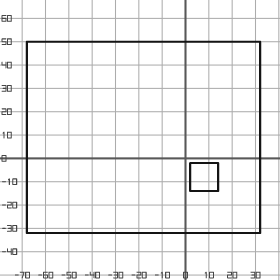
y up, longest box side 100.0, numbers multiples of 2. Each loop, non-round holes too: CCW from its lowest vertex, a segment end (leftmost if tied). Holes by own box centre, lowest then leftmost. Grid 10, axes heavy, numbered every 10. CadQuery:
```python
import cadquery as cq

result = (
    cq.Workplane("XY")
    .moveTo(-68.0, -32.0)
    .lineTo(32.0, -32.0)
    .lineTo(32.0, 50.0)
    .lineTo(-68.0, 50.0)
    .close()
    .moveTo(2.0, -14.0)
    .lineTo(14.0, -14.0)
    .lineTo(14.0, -2.0)
    .lineTo(2.0, -2.0)
    .close()
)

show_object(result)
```